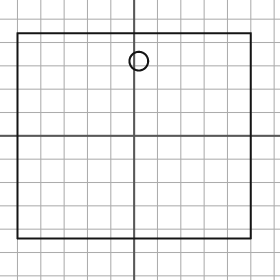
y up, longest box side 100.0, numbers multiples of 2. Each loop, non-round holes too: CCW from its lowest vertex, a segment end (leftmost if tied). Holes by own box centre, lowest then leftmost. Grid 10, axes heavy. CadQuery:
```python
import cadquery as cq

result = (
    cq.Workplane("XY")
    .moveTo(-50.0, -44.0)
    .lineTo(50.0, -44.0)
    .lineTo(50.0, 44.0)
    .lineTo(-50.0, 44.0)
    .close()
    .moveTo(2.0, 32.0)
    .circle(4.0)
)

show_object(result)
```